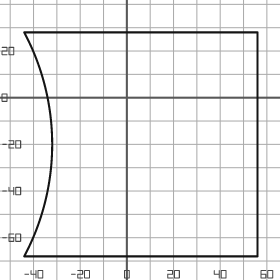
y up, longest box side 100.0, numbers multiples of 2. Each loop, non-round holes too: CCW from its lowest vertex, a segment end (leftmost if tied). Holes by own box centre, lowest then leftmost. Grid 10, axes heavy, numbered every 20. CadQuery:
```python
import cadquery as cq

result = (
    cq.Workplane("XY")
    .moveTo(-44.0, -68.0)
    .lineTo(56.0, -68.0)
    .lineTo(56.0, 28.0)
    .lineTo(-44.0, 28.0)
    .threePointArc((-32.0, -20.0), (-44.0, -68.0))
    .close()
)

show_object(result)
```